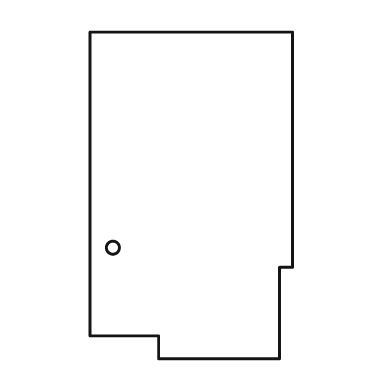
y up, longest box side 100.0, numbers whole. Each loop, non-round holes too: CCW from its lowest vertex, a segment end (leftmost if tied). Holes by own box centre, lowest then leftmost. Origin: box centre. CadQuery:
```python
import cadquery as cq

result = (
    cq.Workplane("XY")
    .moveTo(-10.0, -50.0)
    .lineTo(27.0, -50.0)
    .lineTo(27.0, -22.0)
    .lineTo(31.0, -22.0)
    .lineTo(31.0, 50.0)
    .lineTo(-31.0, 50.0)
    .lineTo(-31.0, -43.0)
    .lineTo(-10.0, -43.0)
    .close()
    .moveTo(-24.0, -16.0)
    .circle(2.0)
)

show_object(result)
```